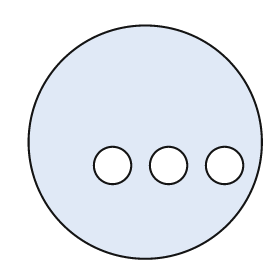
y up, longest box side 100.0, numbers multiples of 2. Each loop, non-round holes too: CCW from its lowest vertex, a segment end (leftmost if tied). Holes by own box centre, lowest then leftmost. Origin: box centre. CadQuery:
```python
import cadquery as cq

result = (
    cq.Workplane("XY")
    .moveTo(0.0, 0.0)
    .circle(50.0)
    .moveTo(-14.0, -10.0)
    .circle(8.0)
    .moveTo(10.0, -10.0)
    .circle(8.0)
    .moveTo(34.0, -10.0)
    .circle(8.0)
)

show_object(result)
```